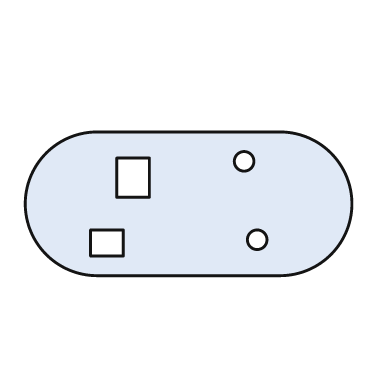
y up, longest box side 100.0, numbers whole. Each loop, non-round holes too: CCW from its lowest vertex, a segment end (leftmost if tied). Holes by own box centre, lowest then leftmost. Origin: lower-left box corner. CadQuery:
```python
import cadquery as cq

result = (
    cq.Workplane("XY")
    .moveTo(22.0, 0.0)
    .lineTo(78.0, 0.0)
    .threePointArc((100.0, 22.0), (78.0, 44.0))
    .lineTo(22.0, 44.0)
    .threePointArc((0.0, 22.0), (22.0, 0.0))
    .close()
    .moveTo(20.0, 6.0)
    .lineTo(30.0, 6.0)
    .lineTo(30.0, 14.0)
    .lineTo(20.0, 14.0)
    .close()
    .moveTo(71.0, 11.0)
    .circle(3.0)
    .moveTo(28.0, 24.0)
    .lineTo(38.0, 24.0)
    .lineTo(38.0, 36.0)
    .lineTo(28.0, 36.0)
    .close()
    .moveTo(67.0, 35.0)
    .circle(3.0)
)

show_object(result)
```